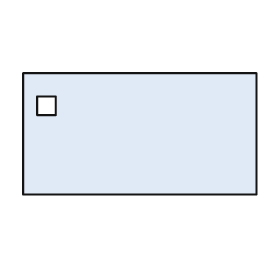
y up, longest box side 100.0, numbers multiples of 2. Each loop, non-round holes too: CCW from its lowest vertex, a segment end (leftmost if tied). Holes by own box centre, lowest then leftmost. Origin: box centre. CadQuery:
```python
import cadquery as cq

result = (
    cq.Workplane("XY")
    .moveTo(-50.0, -26.0)
    .lineTo(50.0, -26.0)
    .lineTo(50.0, 26.0)
    .lineTo(-50.0, 26.0)
    .close()
    .moveTo(-44.0, 8.0)
    .lineTo(-36.0, 8.0)
    .lineTo(-36.0, 16.0)
    .lineTo(-44.0, 16.0)
    .close()
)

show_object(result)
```